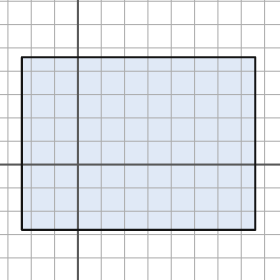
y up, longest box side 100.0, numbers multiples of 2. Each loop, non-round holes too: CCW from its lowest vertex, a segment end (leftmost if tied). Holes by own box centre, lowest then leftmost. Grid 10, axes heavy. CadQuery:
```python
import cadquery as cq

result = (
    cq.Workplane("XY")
    .moveTo(-24.0, -28.0)
    .lineTo(76.0, -28.0)
    .lineTo(76.0, 46.0)
    .lineTo(-24.0, 46.0)
    .close()
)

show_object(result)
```